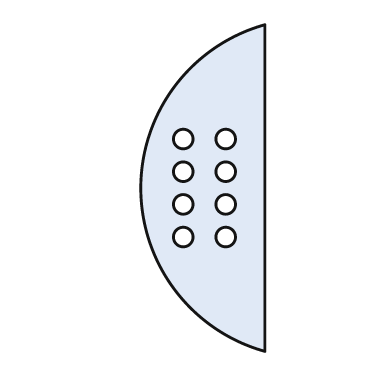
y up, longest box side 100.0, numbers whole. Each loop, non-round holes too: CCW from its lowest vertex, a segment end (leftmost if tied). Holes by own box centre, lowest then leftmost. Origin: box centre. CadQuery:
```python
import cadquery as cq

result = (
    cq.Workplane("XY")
    .moveTo(19.0, -50.0)
    .lineTo(19.0, 50.0)
    .threePointArc((-19.0, 0.0), (19.0, -50.0))
    .close()
    .moveTo(-6.0, -15.0)
    .circle(3.0)
    .moveTo(7.0, -15.0)
    .circle(3.0)
    .moveTo(-6.0, -5.0)
    .circle(3.0)
    .moveTo(7.0, -5.0)
    .circle(3.0)
    .moveTo(-6.0, 5.0)
    .circle(3.0)
    .moveTo(7.0, 5.0)
    .circle(3.0)
    .moveTo(-6.0, 15.0)
    .circle(3.0)
    .moveTo(7.0, 15.0)
    .circle(3.0)
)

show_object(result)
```